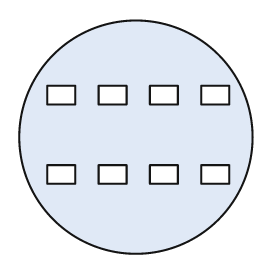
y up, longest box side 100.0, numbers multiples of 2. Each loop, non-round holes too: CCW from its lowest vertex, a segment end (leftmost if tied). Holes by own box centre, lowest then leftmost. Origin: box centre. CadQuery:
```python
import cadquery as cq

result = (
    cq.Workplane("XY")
    .moveTo(0.0, 0.0)
    .circle(50.0)
    .moveTo(-38.0, -20.0)
    .lineTo(-26.0, -20.0)
    .lineTo(-26.0, -12.0)
    .lineTo(-38.0, -12.0)
    .close()
    .moveTo(-16.0, -20.0)
    .lineTo(-4.0, -20.0)
    .lineTo(-4.0, -12.0)
    .lineTo(-16.0, -12.0)
    .close()
    .moveTo(6.0, -20.0)
    .lineTo(18.0, -20.0)
    .lineTo(18.0, -12.0)
    .lineTo(6.0, -12.0)
    .close()
    .moveTo(28.0, -20.0)
    .lineTo(40.0, -20.0)
    .lineTo(40.0, -12.0)
    .lineTo(28.0, -12.0)
    .close()
    .moveTo(-38.0, 14.0)
    .lineTo(-26.0, 14.0)
    .lineTo(-26.0, 22.0)
    .lineTo(-38.0, 22.0)
    .close()
    .moveTo(-16.0, 14.0)
    .lineTo(-4.0, 14.0)
    .lineTo(-4.0, 22.0)
    .lineTo(-16.0, 22.0)
    .close()
    .moveTo(6.0, 14.0)
    .lineTo(18.0, 14.0)
    .lineTo(18.0, 22.0)
    .lineTo(6.0, 22.0)
    .close()
    .moveTo(28.0, 14.0)
    .lineTo(40.0, 14.0)
    .lineTo(40.0, 22.0)
    .lineTo(28.0, 22.0)
    .close()
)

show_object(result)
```